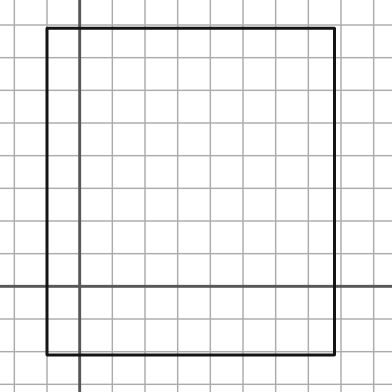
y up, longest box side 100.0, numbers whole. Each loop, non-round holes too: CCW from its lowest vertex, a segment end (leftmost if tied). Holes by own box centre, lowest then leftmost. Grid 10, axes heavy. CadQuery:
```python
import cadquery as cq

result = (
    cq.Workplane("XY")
    .moveTo(-10.0, -21.0)
    .lineTo(78.0, -21.0)
    .lineTo(78.0, 79.0)
    .lineTo(-10.0, 79.0)
    .close()
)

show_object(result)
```